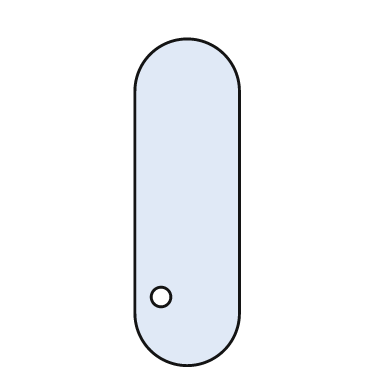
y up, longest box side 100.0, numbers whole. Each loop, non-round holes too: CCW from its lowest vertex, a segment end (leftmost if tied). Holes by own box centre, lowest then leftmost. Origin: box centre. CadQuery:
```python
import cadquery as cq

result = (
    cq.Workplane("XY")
    .moveTo(-16.0, -34.0)
    .threePointArc((0.0, -50.0), (16.0, -34.0))
    .lineTo(16.0, 34.0)
    .threePointArc((0.0, 50.0), (-16.0, 34.0))
    .close()
    .moveTo(-8.0, -29.0)
    .circle(3.0)
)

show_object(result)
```